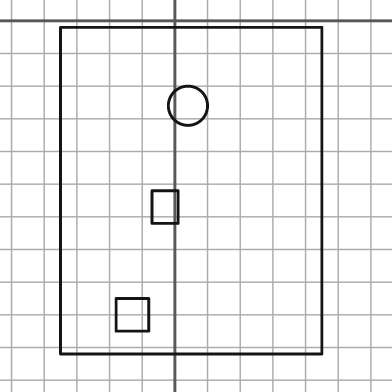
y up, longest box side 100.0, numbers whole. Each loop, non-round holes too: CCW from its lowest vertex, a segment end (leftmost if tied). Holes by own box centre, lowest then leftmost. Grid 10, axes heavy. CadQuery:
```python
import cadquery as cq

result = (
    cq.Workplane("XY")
    .moveTo(-35.0, -102.0)
    .lineTo(45.0, -102.0)
    .lineTo(45.0, -2.0)
    .lineTo(-35.0, -2.0)
    .close()
    .moveTo(-18.0, -95.0)
    .lineTo(-8.0, -95.0)
    .lineTo(-8.0, -85.0)
    .lineTo(-18.0, -85.0)
    .close()
    .moveTo(-7.0, -62.0)
    .lineTo(1.0, -62.0)
    .lineTo(1.0, -52.0)
    .lineTo(-7.0, -52.0)
    .close()
    .moveTo(4.0, -26.0)
    .circle(6.0)
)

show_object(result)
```